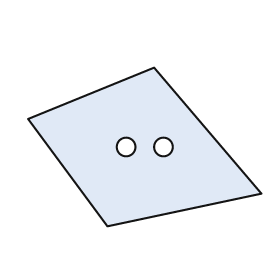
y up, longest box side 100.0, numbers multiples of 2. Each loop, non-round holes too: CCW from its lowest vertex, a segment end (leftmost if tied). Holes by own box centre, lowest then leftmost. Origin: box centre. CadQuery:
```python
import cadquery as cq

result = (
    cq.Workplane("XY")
    .moveTo(-16.0, -34.0)
    .lineTo(50.0, -20.0)
    .lineTo(4.0, 34.0)
    .lineTo(-50.0, 12.0)
    .close()
    .moveTo(-8.0, 0.0)
    .circle(4.0)
    .moveTo(8.0, 0.0)
    .circle(4.0)
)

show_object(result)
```